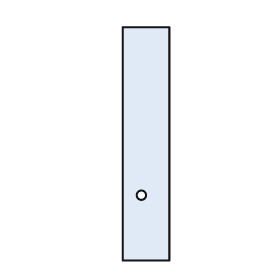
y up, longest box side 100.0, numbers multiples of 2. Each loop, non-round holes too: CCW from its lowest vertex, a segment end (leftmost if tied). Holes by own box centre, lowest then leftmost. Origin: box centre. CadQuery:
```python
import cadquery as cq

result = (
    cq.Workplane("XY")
    .moveTo(-10.0, -50.0)
    .lineTo(10.0, -50.0)
    .lineTo(10.0, 50.0)
    .lineTo(-10.0, 50.0)
    .close()
    .moveTo(-2.0, -22.0)
    .circle(2.0)
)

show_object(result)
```